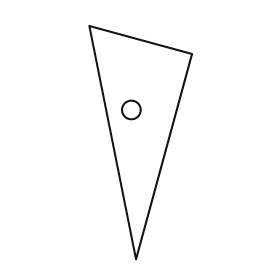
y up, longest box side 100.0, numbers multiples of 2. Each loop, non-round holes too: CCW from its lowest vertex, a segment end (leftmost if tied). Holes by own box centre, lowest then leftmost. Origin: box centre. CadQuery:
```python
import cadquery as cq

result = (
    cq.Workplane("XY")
    .moveTo(-2.0, -50.0)
    .lineTo(22.0, 38.0)
    .lineTo(-22.0, 50.0)
    .close()
    .moveTo(-4.0, 14.0)
    .circle(4.0)
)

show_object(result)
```